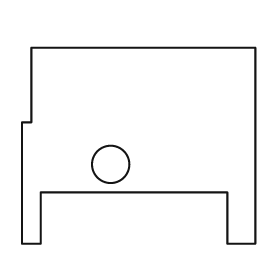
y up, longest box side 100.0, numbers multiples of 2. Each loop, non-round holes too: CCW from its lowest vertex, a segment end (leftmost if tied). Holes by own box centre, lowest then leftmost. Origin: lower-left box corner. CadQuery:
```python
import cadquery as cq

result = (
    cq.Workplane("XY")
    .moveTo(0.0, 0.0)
    .lineTo(8.0, 0.0)
    .lineTo(8.0, 22.0)
    .lineTo(88.0, 22.0)
    .lineTo(88.0, 0.0)
    .lineTo(100.0, 0.0)
    .lineTo(100.0, 84.0)
    .lineTo(4.0, 84.0)
    .lineTo(4.0, 52.0)
    .lineTo(0.0, 52.0)
    .close()
    .moveTo(38.0, 34.0)
    .circle(8.0)
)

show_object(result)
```